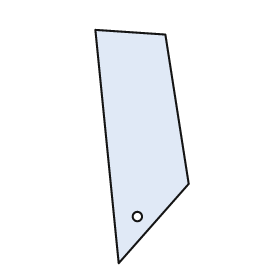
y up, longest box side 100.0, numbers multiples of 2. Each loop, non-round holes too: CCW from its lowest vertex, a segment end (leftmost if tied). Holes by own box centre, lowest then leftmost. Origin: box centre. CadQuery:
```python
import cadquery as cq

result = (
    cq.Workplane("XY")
    .moveTo(-10.0, -50.0)
    .lineTo(20.0, -16.0)
    .lineTo(10.0, 48.0)
    .lineTo(-20.0, 50.0)
    .close()
    .moveTo(-2.0, -30.0)
    .circle(2.0)
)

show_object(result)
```